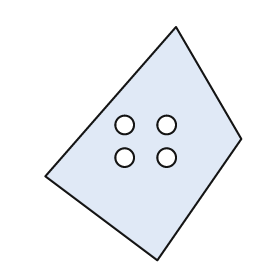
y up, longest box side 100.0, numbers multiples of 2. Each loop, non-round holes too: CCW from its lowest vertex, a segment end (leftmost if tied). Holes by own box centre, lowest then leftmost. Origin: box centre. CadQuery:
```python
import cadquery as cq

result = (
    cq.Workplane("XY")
    .moveTo(6.0, -50.0)
    .lineTo(42.0, 2.0)
    .lineTo(14.0, 50.0)
    .lineTo(-42.0, -14.0)
    .close()
    .moveTo(-8.0, -6.0)
    .circle(4.0)
    .moveTo(10.0, -6.0)
    .circle(4.0)
    .moveTo(-8.0, 8.0)
    .circle(4.0)
    .moveTo(10.0, 8.0)
    .circle(4.0)
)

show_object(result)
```